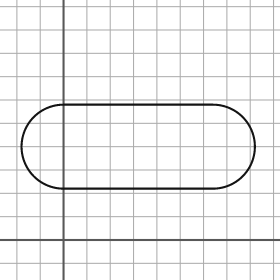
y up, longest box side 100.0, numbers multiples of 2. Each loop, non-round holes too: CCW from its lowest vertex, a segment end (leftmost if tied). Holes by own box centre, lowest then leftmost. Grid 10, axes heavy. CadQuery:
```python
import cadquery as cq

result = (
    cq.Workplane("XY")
    .moveTo(0.0, 22.0)
    .lineTo(64.0, 22.0)
    .threePointArc((82.0, 40.0), (64.0, 58.0))
    .lineTo(0.0, 58.0)
    .threePointArc((-18.0, 40.0), (0.0, 22.0))
    .close()
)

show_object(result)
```